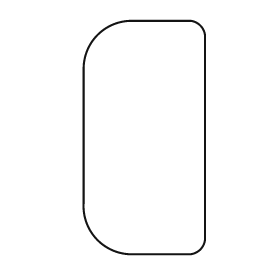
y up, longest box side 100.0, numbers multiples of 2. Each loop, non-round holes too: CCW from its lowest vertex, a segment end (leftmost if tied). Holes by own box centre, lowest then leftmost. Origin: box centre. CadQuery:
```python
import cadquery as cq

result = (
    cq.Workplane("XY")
    .moveTo(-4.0, -50.0)
    .lineTo(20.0, -50.0)
    .threePointArc((24.0, -48.0), (26.0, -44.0))
    .lineTo(26.0, 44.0)
    .threePointArc((24.0, 48.0), (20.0, 50.0))
    .lineTo(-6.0, 50.0)
    .threePointArc((-20.0, 44.0), (-26.0, 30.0))
    .lineTo(-26.0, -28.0)
    .threePointArc((-20.0, -44.0), (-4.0, -50.0))
    .close()
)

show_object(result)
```